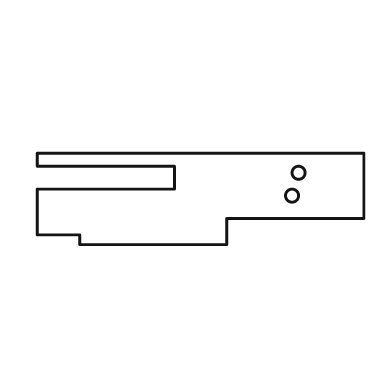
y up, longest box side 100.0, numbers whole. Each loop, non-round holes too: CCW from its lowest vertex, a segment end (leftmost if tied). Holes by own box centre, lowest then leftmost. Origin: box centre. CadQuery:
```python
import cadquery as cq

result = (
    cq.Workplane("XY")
    .moveTo(-37.0, -14.0)
    .lineTo(8.0, -14.0)
    .lineTo(8.0, -6.0)
    .lineTo(50.0, -6.0)
    .lineTo(50.0, 14.0)
    .lineTo(-50.0, 14.0)
    .lineTo(-50.0, 10.0)
    .lineTo(-8.0, 10.0)
    .lineTo(-8.0, 3.0)
    .lineTo(-50.0, 3.0)
    .lineTo(-50.0, -11.0)
    .lineTo(-37.0, -11.0)
    .close()
    .moveTo(28.0, 1.0)
    .circle(2.0)
    .moveTo(30.0, 8.0)
    .circle(2.0)
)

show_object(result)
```